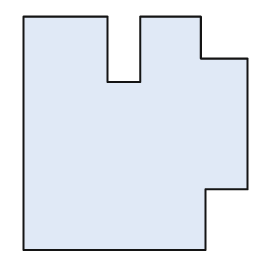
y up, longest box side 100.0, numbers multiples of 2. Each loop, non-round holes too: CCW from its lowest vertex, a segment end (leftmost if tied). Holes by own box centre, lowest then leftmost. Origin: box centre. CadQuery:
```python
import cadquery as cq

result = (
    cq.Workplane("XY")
    .moveTo(-48.0, -50.0)
    .lineTo(30.0, -50.0)
    .lineTo(30.0, -24.0)
    .lineTo(48.0, -24.0)
    .lineTo(48.0, 32.0)
    .lineTo(28.0, 32.0)
    .lineTo(28.0, 50.0)
    .lineTo(2.0, 50.0)
    .lineTo(2.0, 22.0)
    .lineTo(-12.0, 22.0)
    .lineTo(-12.0, 50.0)
    .lineTo(-48.0, 50.0)
    .close()
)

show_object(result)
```